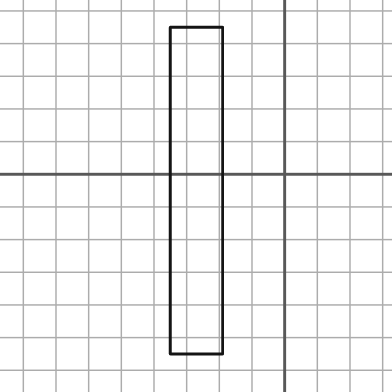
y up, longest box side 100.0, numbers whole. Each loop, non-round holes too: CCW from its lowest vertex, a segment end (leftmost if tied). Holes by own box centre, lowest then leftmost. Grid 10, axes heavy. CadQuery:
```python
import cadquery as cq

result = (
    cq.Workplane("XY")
    .moveTo(-35.0, -55.0)
    .lineTo(-19.0, -55.0)
    .lineTo(-19.0, 45.0)
    .lineTo(-35.0, 45.0)
    .close()
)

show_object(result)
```